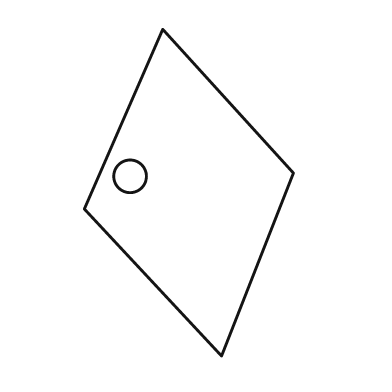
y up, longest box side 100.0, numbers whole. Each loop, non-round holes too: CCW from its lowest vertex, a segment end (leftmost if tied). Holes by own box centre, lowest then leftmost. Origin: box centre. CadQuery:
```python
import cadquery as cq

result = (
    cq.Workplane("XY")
    .moveTo(10.0, -50.0)
    .lineTo(32.0, 6.0)
    .lineTo(-8.0, 50.0)
    .lineTo(-32.0, -5.0)
    .close()
    .moveTo(-18.0, 5.0)
    .circle(5.0)
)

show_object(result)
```